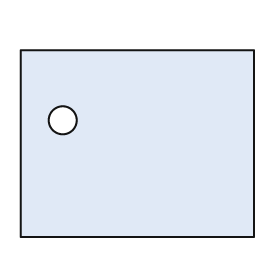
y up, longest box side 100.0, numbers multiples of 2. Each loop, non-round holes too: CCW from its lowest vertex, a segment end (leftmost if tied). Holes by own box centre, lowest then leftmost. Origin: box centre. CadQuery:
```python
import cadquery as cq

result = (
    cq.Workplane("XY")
    .moveTo(-50.0, -40.0)
    .lineTo(50.0, -40.0)
    .lineTo(50.0, 40.0)
    .lineTo(-50.0, 40.0)
    .close()
    .moveTo(-32.0, 10.0)
    .circle(6.0)
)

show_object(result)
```